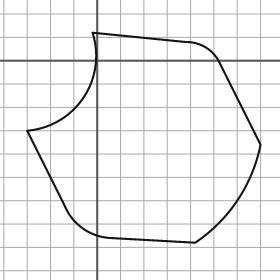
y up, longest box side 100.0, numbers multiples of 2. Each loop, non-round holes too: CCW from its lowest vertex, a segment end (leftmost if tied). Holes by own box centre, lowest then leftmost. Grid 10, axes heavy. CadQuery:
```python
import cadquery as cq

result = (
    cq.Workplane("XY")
    .moveTo(42.0, -78.0)
    .threePointArc((60.0, -60.0), (70.0, -36.0))
    .lineTo(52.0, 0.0)
    .threePointArc((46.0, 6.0), (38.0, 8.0))
    .lineTo(-2.0, 12.0)
    .threePointArc((-6.0, -16.0), (-30.0, -30.0))
    .lineTo(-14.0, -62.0)
    .threePointArc((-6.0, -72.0), (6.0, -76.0))
    .close()
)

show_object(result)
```